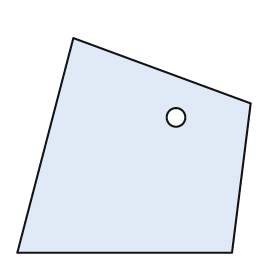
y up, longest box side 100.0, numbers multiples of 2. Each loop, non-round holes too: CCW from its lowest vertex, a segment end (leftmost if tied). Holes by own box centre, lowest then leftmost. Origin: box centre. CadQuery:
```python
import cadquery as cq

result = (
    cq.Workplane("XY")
    .moveTo(-50.0, -46.0)
    .lineTo(42.0, -46.0)
    .lineTo(50.0, 18.0)
    .lineTo(-26.0, 46.0)
    .close()
    .moveTo(18.0, 12.0)
    .circle(4.0)
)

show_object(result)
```